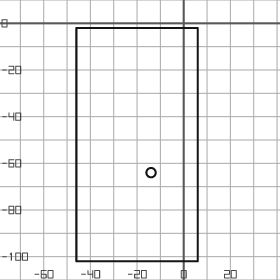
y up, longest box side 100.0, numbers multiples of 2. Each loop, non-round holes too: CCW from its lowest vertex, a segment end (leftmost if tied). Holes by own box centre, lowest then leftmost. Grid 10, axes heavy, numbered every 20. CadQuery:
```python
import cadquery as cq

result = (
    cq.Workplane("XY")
    .moveTo(-46.0, -102.0)
    .lineTo(6.0, -102.0)
    .lineTo(6.0, -2.0)
    .lineTo(-46.0, -2.0)
    .close()
    .moveTo(-14.0, -64.0)
    .circle(2.0)
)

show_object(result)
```